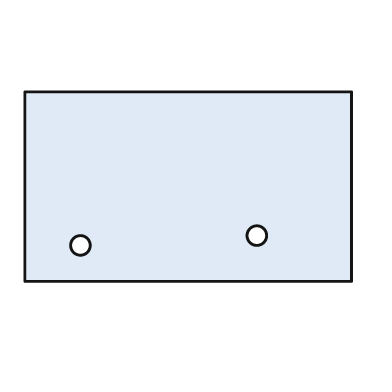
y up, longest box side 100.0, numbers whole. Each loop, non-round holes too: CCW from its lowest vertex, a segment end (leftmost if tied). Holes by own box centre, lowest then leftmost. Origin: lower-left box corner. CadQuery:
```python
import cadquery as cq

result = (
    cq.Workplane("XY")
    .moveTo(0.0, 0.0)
    .lineTo(100.0, 0.0)
    .lineTo(100.0, 58.0)
    .lineTo(0.0, 58.0)
    .close()
    .moveTo(17.0, 11.0)
    .circle(3.0)
    .moveTo(71.0, 14.0)
    .circle(3.0)
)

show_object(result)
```